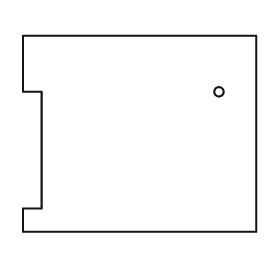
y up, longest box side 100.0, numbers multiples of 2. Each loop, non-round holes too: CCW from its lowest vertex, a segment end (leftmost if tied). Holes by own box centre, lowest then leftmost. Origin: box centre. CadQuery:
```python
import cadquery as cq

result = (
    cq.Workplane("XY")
    .moveTo(-50.0, -42.0)
    .lineTo(50.0, -42.0)
    .lineTo(50.0, 42.0)
    .lineTo(-50.0, 42.0)
    .lineTo(-50.0, 18.0)
    .lineTo(-42.0, 18.0)
    .lineTo(-42.0, -32.0)
    .lineTo(-50.0, -32.0)
    .close()
    .moveTo(34.0, 18.0)
    .circle(2.0)
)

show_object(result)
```